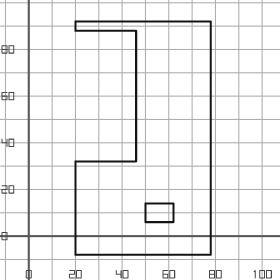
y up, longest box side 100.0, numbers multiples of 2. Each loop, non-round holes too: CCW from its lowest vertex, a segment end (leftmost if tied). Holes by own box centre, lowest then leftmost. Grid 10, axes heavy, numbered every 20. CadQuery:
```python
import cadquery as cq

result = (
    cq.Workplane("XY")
    .moveTo(20.0, -8.0)
    .lineTo(78.0, -8.0)
    .lineTo(78.0, 92.0)
    .lineTo(20.0, 92.0)
    .lineTo(20.0, 88.0)
    .lineTo(46.0, 88.0)
    .lineTo(46.0, 32.0)
    .lineTo(20.0, 32.0)
    .close()
    .moveTo(50.0, 6.0)
    .lineTo(62.0, 6.0)
    .lineTo(62.0, 14.0)
    .lineTo(50.0, 14.0)
    .close()
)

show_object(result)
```